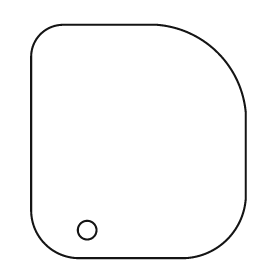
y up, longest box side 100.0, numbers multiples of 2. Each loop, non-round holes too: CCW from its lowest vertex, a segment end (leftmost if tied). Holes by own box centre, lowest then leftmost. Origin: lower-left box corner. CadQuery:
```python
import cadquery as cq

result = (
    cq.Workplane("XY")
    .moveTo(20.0, 0.0)
    .lineTo(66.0, 0.0)
    .threePointArc((84.0, 8.0), (92.0, 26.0))
    .lineTo(92.0, 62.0)
    .threePointArc((80.0, 88.0), (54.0, 100.0))
    .lineTo(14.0, 100.0)
    .threePointArc((4.0, 96.0), (0.0, 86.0))
    .lineTo(0.0, 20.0)
    .threePointArc((6.0, 6.0), (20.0, 0.0))
    .close()
    .moveTo(24.0, 12.0)
    .circle(4.0)
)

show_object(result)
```